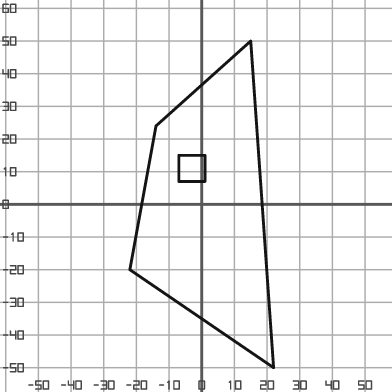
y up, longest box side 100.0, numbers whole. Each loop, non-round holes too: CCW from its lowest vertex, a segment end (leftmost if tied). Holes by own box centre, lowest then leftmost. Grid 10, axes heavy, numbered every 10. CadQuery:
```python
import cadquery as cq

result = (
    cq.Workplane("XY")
    .moveTo(22.0, -50.0)
    .lineTo(15.0, 50.0)
    .lineTo(-14.0, 24.0)
    .lineTo(-22.0, -20.0)
    .close()
    .moveTo(-7.0, 7.0)
    .lineTo(1.0, 7.0)
    .lineTo(1.0, 15.0)
    .lineTo(-7.0, 15.0)
    .close()
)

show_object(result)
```